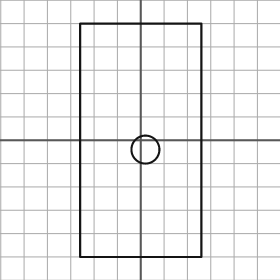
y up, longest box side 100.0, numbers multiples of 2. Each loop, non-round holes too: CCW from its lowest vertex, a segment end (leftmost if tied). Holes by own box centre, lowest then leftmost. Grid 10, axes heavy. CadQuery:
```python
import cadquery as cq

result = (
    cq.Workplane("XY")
    .moveTo(-26.0, -50.0)
    .lineTo(26.0, -50.0)
    .lineTo(26.0, 50.0)
    .lineTo(-26.0, 50.0)
    .close()
    .moveTo(2.0, -4.0)
    .circle(6.0)
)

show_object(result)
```